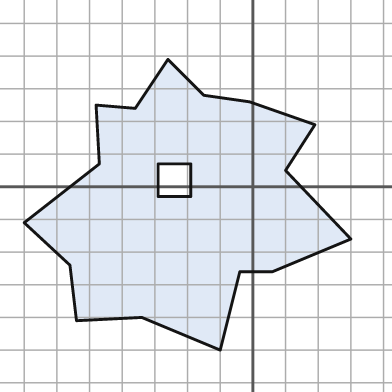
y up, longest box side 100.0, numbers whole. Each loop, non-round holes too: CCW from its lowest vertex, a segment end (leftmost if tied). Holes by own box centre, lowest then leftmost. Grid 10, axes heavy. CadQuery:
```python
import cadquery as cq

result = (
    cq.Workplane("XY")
    .moveTo(-10.0, -50.0)
    .lineTo(-4.0, -26.0)
    .lineTo(6.0, -26.0)
    .lineTo(30.0, -16.0)
    .lineTo(10.0, 5.0)
    .lineTo(19.0, 19.0)
    .lineTo(-1.0, 26.0)
    .lineTo(-15.0, 28.0)
    .lineTo(-26.0, 39.0)
    .lineTo(-36.0, 24.0)
    .lineTo(-48.0, 25.0)
    .lineTo(-47.0, 7.0)
    .lineTo(-70.0, -11.0)
    .lineTo(-56.0, -24.0)
    .lineTo(-54.0, -41.0)
    .lineTo(-34.0, -40.0)
    .close()
    .moveTo(-29.0, -3.0)
    .lineTo(-19.0, -3.0)
    .lineTo(-19.0, 7.0)
    .lineTo(-29.0, 7.0)
    .close()
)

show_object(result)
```